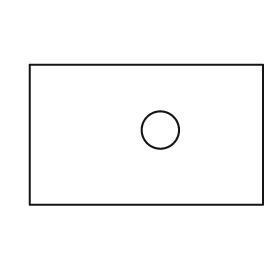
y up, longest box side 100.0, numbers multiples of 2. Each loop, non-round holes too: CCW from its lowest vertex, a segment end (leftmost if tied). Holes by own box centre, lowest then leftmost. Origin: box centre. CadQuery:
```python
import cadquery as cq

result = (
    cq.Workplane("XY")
    .moveTo(-50.0, -30.0)
    .lineTo(50.0, -30.0)
    .lineTo(50.0, 30.0)
    .lineTo(-50.0, 30.0)
    .close()
    .moveTo(6.0, 2.0)
    .circle(8.0)
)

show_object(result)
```